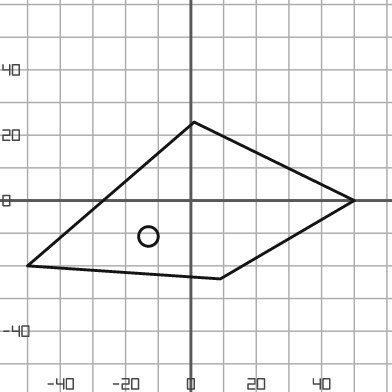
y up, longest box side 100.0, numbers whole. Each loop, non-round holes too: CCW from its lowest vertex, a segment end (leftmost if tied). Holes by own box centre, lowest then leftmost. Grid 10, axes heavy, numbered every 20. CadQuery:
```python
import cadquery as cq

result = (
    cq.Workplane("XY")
    .moveTo(9.0, -24.0)
    .lineTo(50.0, 0.0)
    .lineTo(1.0, 24.0)
    .lineTo(-50.0, -20.0)
    .close()
    .moveTo(-13.0, -11.0)
    .circle(3.0)
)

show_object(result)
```